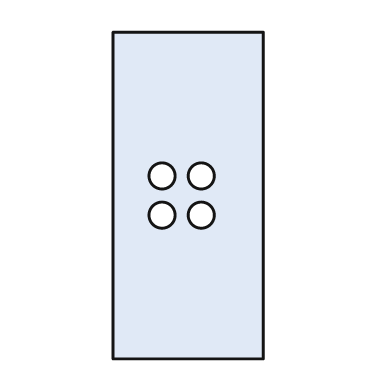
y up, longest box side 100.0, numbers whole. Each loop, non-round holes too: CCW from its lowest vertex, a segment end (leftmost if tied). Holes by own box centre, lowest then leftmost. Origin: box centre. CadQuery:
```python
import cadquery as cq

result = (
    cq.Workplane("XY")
    .moveTo(-23.0, -50.0)
    .lineTo(23.0, -50.0)
    .lineTo(23.0, 50.0)
    .lineTo(-23.0, 50.0)
    .close()
    .moveTo(-8.0, -6.0)
    .circle(4.0)
    .moveTo(4.0, -6.0)
    .circle(4.0)
    .moveTo(-8.0, 6.0)
    .circle(4.0)
    .moveTo(4.0, 6.0)
    .circle(4.0)
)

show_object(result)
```